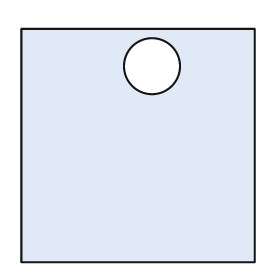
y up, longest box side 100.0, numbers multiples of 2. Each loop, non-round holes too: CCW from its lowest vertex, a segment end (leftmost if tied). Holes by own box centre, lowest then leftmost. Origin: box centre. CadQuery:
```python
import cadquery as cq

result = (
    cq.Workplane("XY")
    .moveTo(-50.0, -50.0)
    .lineTo(50.0, -50.0)
    .lineTo(50.0, 50.0)
    .lineTo(-50.0, 50.0)
    .close()
    .moveTo(6.0, 34.0)
    .circle(12.0)
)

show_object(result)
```